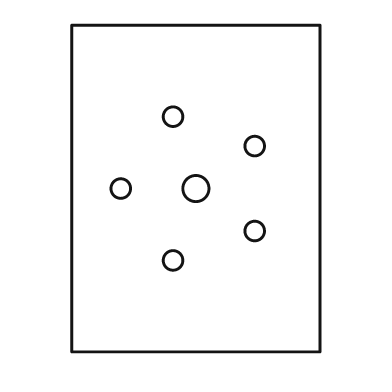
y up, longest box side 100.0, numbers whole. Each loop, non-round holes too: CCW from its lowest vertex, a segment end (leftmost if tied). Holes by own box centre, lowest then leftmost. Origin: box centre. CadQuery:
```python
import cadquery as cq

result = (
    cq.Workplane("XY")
    .moveTo(-38.0, -50.0)
    .lineTo(38.0, -50.0)
    .lineTo(38.0, 50.0)
    .lineTo(-38.0, 50.0)
    .close()
    .moveTo(-7.0, -22.0)
    .circle(3.0)
    .moveTo(18.0, -13.0)
    .circle(3.0)
    .moveTo(-23.0, 0.0)
    .circle(3.0)
    .moveTo(0.0, 0.0)
    .circle(4.0)
    .moveTo(18.0, 13.0)
    .circle(3.0)
    .moveTo(-7.0, 22.0)
    .circle(3.0)
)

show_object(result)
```